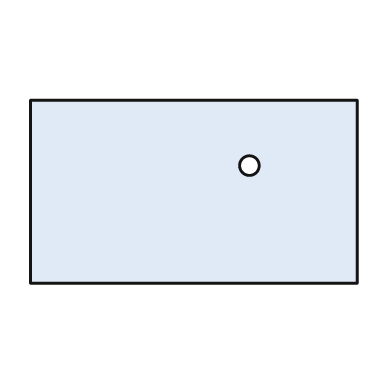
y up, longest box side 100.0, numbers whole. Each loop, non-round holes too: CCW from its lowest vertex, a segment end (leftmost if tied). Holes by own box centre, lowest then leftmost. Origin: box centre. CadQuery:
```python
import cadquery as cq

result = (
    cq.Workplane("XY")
    .moveTo(-50.0, -28.0)
    .lineTo(50.0, -28.0)
    .lineTo(50.0, 28.0)
    .lineTo(-50.0, 28.0)
    .close()
    .moveTo(17.0, 8.0)
    .circle(3.0)
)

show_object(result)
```